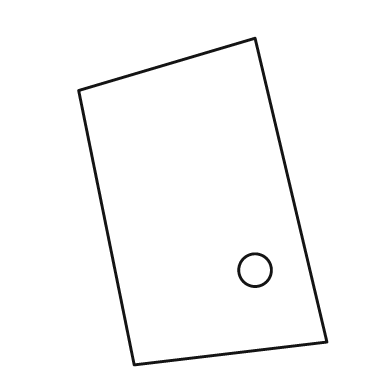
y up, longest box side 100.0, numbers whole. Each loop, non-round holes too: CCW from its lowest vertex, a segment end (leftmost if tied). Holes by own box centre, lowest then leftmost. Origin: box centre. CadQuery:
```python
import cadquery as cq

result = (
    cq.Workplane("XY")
    .moveTo(-21.0, -50.0)
    .lineTo(38.0, -43.0)
    .lineTo(16.0, 50.0)
    .lineTo(-38.0, 34.0)
    .close()
    .moveTo(16.0, -21.0)
    .circle(5.0)
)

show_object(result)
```